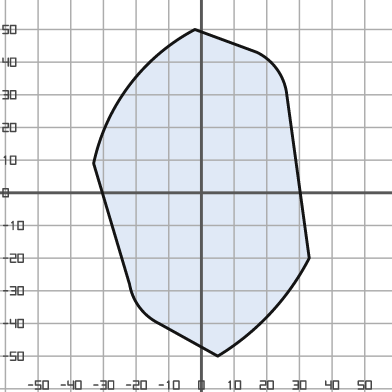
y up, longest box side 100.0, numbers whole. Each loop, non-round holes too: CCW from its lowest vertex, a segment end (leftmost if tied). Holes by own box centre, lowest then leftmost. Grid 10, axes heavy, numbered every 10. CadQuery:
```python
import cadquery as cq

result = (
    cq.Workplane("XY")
    .moveTo(5.0, -50.0)
    .threePointArc((21.0, -37.0), (33.0, -20.0))
    .lineTo(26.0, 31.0)
    .threePointArc((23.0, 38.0), (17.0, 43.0))
    .lineTo(-2.0, 50.0)
    .threePointArc((-22.0, 33.0), (-33.0, 9.0))
    .lineTo(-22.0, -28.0)
    .threePointArc((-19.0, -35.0), (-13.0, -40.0))
    .close()
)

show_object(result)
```